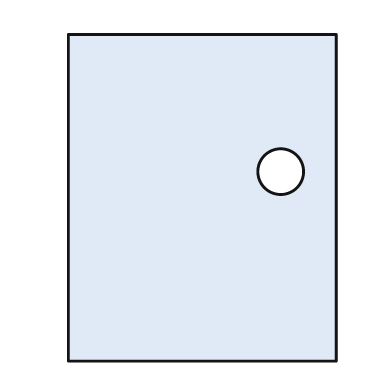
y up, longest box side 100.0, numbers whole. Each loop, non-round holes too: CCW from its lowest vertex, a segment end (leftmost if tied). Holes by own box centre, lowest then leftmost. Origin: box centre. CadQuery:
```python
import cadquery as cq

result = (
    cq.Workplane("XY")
    .moveTo(-41.0, -50.0)
    .lineTo(41.0, -50.0)
    .lineTo(41.0, 50.0)
    .lineTo(-41.0, 50.0)
    .close()
    .moveTo(24.0, 8.0)
    .circle(7.0)
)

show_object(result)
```